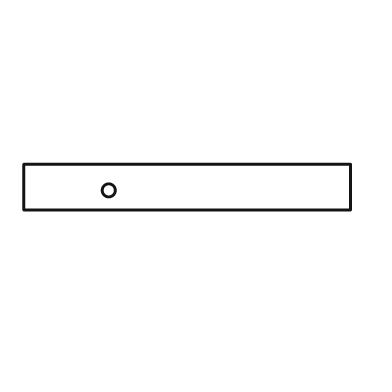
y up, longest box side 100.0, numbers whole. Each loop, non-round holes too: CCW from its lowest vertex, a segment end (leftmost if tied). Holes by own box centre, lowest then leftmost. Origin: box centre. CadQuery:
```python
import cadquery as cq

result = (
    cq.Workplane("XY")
    .moveTo(-50.0, -7.0)
    .lineTo(50.0, -7.0)
    .lineTo(50.0, 7.0)
    .lineTo(-50.0, 7.0)
    .close()
    .moveTo(-24.0, -1.0)
    .circle(2.0)
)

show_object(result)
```